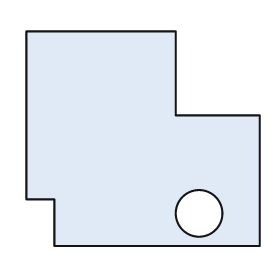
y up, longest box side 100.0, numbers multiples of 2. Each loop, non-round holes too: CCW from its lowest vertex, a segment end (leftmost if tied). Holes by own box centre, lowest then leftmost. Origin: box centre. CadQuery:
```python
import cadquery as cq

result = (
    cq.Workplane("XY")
    .moveTo(-38.0, -46.0)
    .lineTo(50.0, -46.0)
    .lineTo(50.0, 10.0)
    .lineTo(14.0, 10.0)
    .lineTo(14.0, 46.0)
    .lineTo(-50.0, 46.0)
    .lineTo(-50.0, -26.0)
    .lineTo(-38.0, -26.0)
    .close()
    .moveTo(24.0, -32.0)
    .circle(10.0)
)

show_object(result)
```